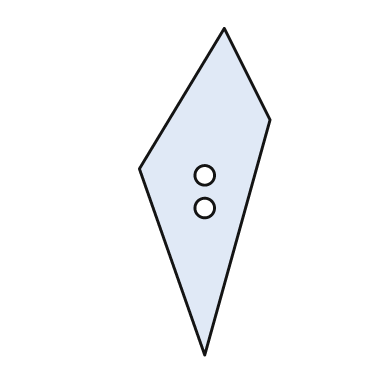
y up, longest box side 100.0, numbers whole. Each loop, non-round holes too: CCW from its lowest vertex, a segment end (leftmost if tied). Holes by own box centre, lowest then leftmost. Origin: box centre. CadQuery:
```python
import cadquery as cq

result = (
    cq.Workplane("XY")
    .moveTo(0.0, -50.0)
    .lineTo(20.0, 22.0)
    .lineTo(6.0, 50.0)
    .lineTo(-20.0, 7.0)
    .close()
    .moveTo(0.0, -5.0)
    .circle(3.0)
    .moveTo(0.0, 5.0)
    .circle(3.0)
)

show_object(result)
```